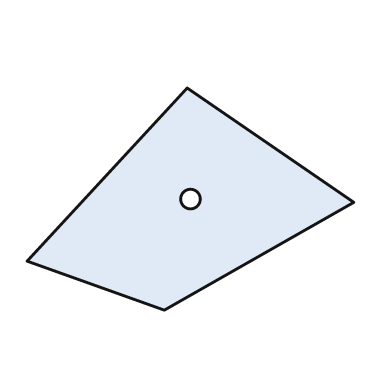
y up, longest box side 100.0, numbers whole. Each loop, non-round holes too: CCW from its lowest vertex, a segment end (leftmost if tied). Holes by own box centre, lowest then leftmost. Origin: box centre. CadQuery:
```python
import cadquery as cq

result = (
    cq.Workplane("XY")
    .moveTo(-8.0, -34.0)
    .lineTo(50.0, -1.0)
    .lineTo(-1.0, 34.0)
    .lineTo(-50.0, -19.0)
    .close()
    .moveTo(0.0, 0.0)
    .circle(3.0)
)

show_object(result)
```